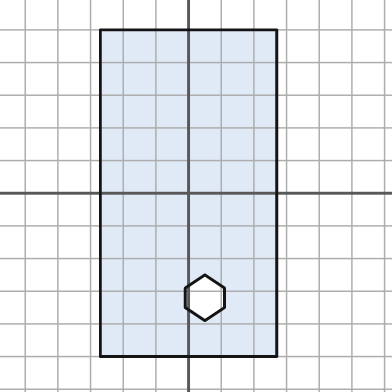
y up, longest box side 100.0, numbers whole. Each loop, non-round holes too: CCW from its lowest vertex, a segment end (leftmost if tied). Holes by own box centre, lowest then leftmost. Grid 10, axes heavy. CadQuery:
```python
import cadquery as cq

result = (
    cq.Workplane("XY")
    .moveTo(-27.0, -50.0)
    .lineTo(27.0, -50.0)
    .lineTo(27.0, 50.0)
    .lineTo(-27.0, 50.0)
    .close()
    .moveTo(5.0, -39.0)
    .lineTo(11.0, -35.0)
    .lineTo(11.0, -29.0)
    .lineTo(5.0, -25.0)
    .lineTo(-1.0, -29.0)
    .lineTo(-1.0, -35.0)
    .close()
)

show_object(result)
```